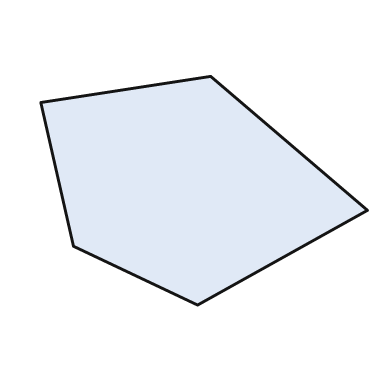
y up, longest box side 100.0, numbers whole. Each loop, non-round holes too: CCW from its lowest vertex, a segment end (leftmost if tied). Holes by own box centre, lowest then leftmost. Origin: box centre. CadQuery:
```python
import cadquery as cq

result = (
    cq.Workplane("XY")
    .moveTo(-2.0, -35.0)
    .lineTo(50.0, -6.0)
    .lineTo(2.0, 35.0)
    .lineTo(-50.0, 27.0)
    .lineTo(-40.0, -17.0)
    .close()
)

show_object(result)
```